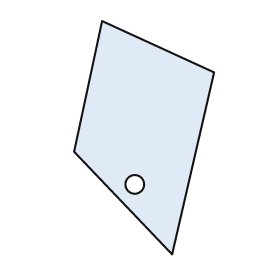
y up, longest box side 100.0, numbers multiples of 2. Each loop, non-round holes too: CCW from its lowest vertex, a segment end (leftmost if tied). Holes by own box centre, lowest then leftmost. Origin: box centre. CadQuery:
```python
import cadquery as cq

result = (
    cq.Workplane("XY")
    .moveTo(12.0, -50.0)
    .lineTo(30.0, 28.0)
    .lineTo(-18.0, 50.0)
    .lineTo(-30.0, -6.0)
    .close()
    .moveTo(-4.0, -20.0)
    .circle(4.0)
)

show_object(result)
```